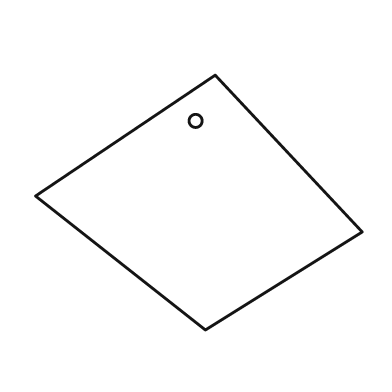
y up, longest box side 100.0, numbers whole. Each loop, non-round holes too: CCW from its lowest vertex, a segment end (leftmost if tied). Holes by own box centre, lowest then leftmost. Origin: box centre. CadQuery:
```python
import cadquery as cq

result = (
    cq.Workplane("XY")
    .moveTo(2.0, -39.0)
    .lineTo(50.0, -9.0)
    .lineTo(5.0, 39.0)
    .lineTo(-50.0, 2.0)
    .close()
    .moveTo(-1.0, 25.0)
    .circle(2.0)
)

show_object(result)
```